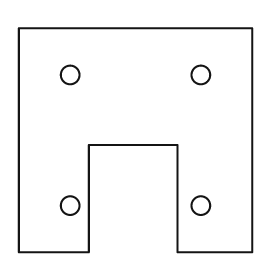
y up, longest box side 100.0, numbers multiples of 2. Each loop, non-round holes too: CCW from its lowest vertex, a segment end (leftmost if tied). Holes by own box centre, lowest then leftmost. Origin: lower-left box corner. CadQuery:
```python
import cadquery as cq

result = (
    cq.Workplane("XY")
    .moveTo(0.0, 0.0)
    .lineTo(30.0, 0.0)
    .lineTo(30.0, 46.0)
    .lineTo(68.0, 46.0)
    .lineTo(68.0, 0.0)
    .lineTo(100.0, 0.0)
    .lineTo(100.0, 96.0)
    .lineTo(0.0, 96.0)
    .close()
    .moveTo(22.0, 20.0)
    .circle(4.0)
    .moveTo(78.0, 20.0)
    .circle(4.0)
    .moveTo(22.0, 76.0)
    .circle(4.0)
    .moveTo(78.0, 76.0)
    .circle(4.0)
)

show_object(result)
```